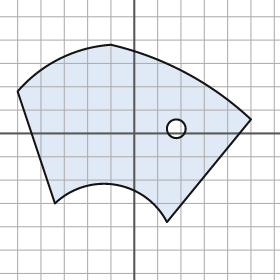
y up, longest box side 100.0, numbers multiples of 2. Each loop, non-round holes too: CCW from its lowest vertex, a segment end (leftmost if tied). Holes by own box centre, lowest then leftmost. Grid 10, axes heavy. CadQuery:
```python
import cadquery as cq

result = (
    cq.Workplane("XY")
    .moveTo(14.0, -38.0)
    .lineTo(50.0, 6.0)
    .threePointArc((22.0, 26.0), (-10.0, 38.0))
    .threePointArc((-32.0, 32.0), (-50.0, 18.0))
    .lineTo(-34.0, -30.0)
    .threePointArc((-8.0, -22.0), (14.0, -38.0))
    .close()
    .moveTo(18.0, 2.0)
    .circle(4.0)
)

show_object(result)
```